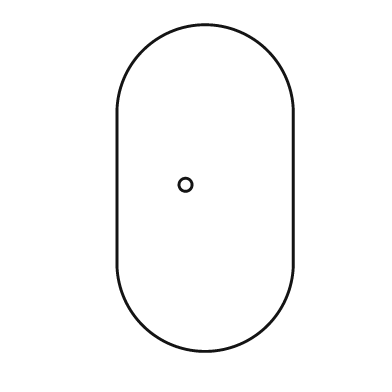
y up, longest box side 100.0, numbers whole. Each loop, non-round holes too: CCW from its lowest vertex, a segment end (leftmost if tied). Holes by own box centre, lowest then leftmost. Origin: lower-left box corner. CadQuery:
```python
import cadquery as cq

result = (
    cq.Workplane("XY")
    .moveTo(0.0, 27.0)
    .threePointArc((27.0, 0.0), (54.0, 27.0))
    .lineTo(54.0, 73.0)
    .threePointArc((27.0, 100.0), (0.0, 73.0))
    .close()
    .moveTo(21.0, 51.0)
    .circle(2.0)
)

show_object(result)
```